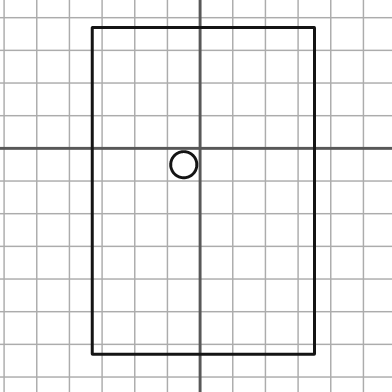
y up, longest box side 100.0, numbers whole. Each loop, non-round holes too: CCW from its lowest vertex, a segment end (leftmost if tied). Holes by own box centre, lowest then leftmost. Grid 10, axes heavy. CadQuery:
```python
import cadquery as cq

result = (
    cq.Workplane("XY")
    .moveTo(-33.0, -63.0)
    .lineTo(35.0, -63.0)
    .lineTo(35.0, 37.0)
    .lineTo(-33.0, 37.0)
    .close()
    .moveTo(-5.0, -5.0)
    .circle(4.0)
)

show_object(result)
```